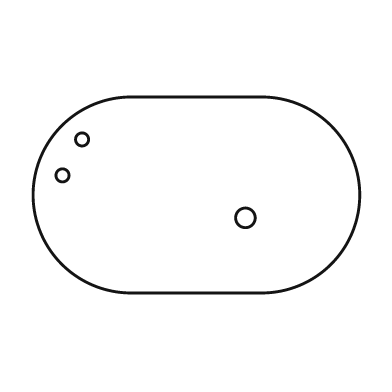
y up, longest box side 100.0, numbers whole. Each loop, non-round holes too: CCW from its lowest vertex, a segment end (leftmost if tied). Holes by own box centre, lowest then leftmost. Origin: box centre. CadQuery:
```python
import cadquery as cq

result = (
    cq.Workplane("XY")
    .moveTo(-20.0, -30.0)
    .lineTo(20.0, -30.0)
    .threePointArc((50.0, 0.0), (20.0, 30.0))
    .lineTo(-20.0, 30.0)
    .threePointArc((-50.0, 0.0), (-20.0, -30.0))
    .close()
    .moveTo(15.0, -7.0)
    .circle(3.0)
    .moveTo(-41.0, 6.0)
    .circle(2.0)
    .moveTo(-35.0, 17.0)
    .circle(2.0)
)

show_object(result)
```